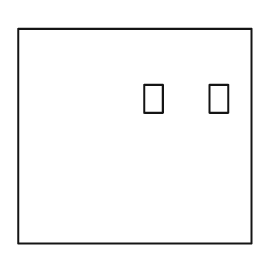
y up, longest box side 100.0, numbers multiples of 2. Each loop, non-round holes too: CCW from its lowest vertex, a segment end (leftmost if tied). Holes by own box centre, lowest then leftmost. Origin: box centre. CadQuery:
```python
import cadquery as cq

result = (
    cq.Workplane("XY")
    .moveTo(-50.0, -46.0)
    .lineTo(50.0, -46.0)
    .lineTo(50.0, 46.0)
    .lineTo(-50.0, 46.0)
    .close()
    .moveTo(4.0, 10.0)
    .lineTo(12.0, 10.0)
    .lineTo(12.0, 22.0)
    .lineTo(4.0, 22.0)
    .close()
    .moveTo(32.0, 10.0)
    .lineTo(40.0, 10.0)
    .lineTo(40.0, 22.0)
    .lineTo(32.0, 22.0)
    .close()
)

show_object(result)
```